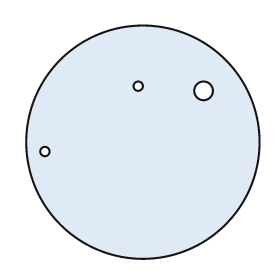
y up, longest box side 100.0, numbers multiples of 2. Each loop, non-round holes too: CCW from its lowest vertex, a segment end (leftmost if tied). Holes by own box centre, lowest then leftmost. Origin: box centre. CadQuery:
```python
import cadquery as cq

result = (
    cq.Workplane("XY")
    .moveTo(0.0, 0.0)
    .circle(50.0)
    .moveTo(-42.0, -4.0)
    .circle(2.0)
    .moveTo(26.0, 22.0)
    .circle(4.0)
    .moveTo(-2.0, 24.0)
    .circle(2.0)
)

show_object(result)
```